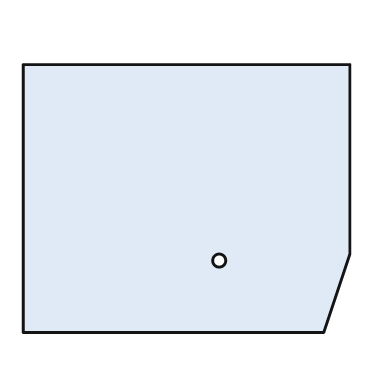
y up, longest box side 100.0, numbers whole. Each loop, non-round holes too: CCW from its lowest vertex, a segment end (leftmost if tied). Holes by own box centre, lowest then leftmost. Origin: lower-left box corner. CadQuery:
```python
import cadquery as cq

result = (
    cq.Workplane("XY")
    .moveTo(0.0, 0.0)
    .lineTo(92.0, 0.0)
    .lineTo(100.0, 24.0)
    .lineTo(100.0, 82.0)
    .lineTo(0.0, 82.0)
    .close()
    .moveTo(60.0, 22.0)
    .circle(2.0)
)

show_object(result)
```